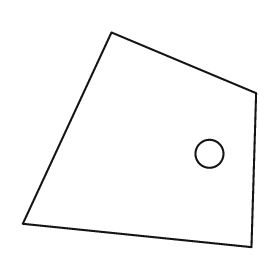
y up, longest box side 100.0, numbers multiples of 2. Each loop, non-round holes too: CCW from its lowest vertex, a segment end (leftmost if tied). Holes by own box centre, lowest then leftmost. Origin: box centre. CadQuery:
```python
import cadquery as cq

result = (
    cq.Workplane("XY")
    .moveTo(48.0, -46.0)
    .lineTo(50.0, 20.0)
    .lineTo(-12.0, 46.0)
    .lineTo(-50.0, -36.0)
    .close()
    .moveTo(30.0, -6.0)
    .circle(6.0)
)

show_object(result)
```